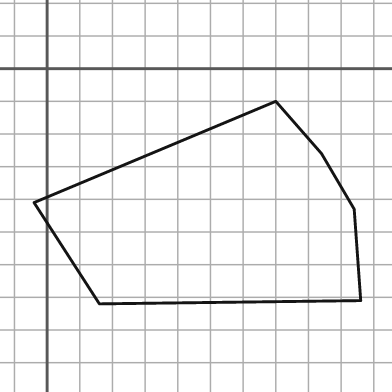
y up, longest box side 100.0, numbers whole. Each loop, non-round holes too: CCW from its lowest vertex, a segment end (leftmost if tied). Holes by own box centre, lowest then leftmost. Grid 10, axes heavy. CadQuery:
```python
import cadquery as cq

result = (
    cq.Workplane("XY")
    .moveTo(16.0, -72.0)
    .lineTo(96.0, -71.0)
    .lineTo(94.0, -43.0)
    .lineTo(84.0, -26.0)
    .lineTo(70.0, -10.0)
    .lineTo(-4.0, -41.0)
    .close()
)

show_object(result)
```